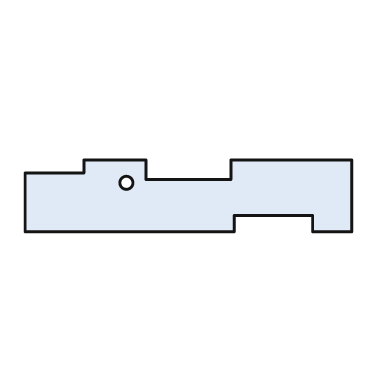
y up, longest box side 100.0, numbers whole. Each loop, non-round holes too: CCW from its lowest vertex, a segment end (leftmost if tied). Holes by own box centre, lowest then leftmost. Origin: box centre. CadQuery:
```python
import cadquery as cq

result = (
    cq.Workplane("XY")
    .moveTo(-50.0, -11.0)
    .lineTo(14.0, -11.0)
    .lineTo(14.0, -6.0)
    .lineTo(38.0, -6.0)
    .lineTo(38.0, -11.0)
    .lineTo(50.0, -11.0)
    .lineTo(50.0, 11.0)
    .lineTo(13.0, 11.0)
    .lineTo(13.0, 5.0)
    .lineTo(-13.0, 5.0)
    .lineTo(-13.0, 11.0)
    .lineTo(-32.0, 11.0)
    .lineTo(-32.0, 7.0)
    .lineTo(-50.0, 7.0)
    .close()
    .moveTo(-19.0, 4.0)
    .circle(2.0)
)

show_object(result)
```